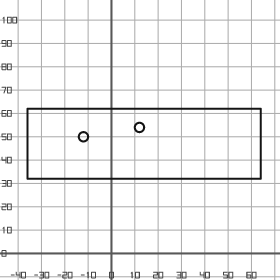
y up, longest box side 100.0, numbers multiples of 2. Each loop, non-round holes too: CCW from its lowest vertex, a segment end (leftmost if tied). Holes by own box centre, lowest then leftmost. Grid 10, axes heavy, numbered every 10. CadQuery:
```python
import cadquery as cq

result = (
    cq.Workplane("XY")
    .moveTo(-36.0, 32.0)
    .lineTo(64.0, 32.0)
    .lineTo(64.0, 62.0)
    .lineTo(-36.0, 62.0)
    .close()
    .moveTo(-12.0, 50.0)
    .circle(2.0)
    .moveTo(12.0, 54.0)
    .circle(2.0)
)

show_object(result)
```